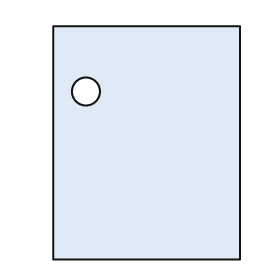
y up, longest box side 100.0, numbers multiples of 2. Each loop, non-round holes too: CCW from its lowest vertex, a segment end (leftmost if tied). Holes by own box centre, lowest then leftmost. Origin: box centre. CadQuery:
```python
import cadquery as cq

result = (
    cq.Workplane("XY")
    .moveTo(-40.0, -50.0)
    .lineTo(40.0, -50.0)
    .lineTo(40.0, 50.0)
    .lineTo(-40.0, 50.0)
    .close()
    .moveTo(-26.0, 22.0)
    .circle(6.0)
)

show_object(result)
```